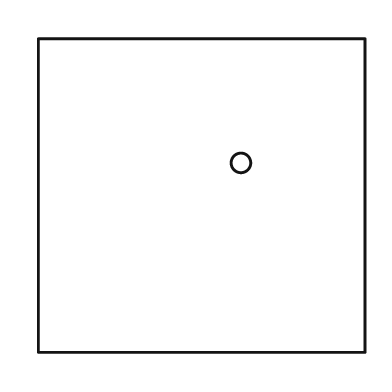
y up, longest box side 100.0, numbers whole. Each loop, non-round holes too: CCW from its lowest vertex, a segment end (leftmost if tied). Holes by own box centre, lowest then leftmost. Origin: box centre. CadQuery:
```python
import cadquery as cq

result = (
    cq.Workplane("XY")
    .moveTo(-50.0, -48.0)
    .lineTo(50.0, -48.0)
    .lineTo(50.0, 48.0)
    .lineTo(-50.0, 48.0)
    .close()
    .moveTo(12.0, 10.0)
    .circle(3.0)
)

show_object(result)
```